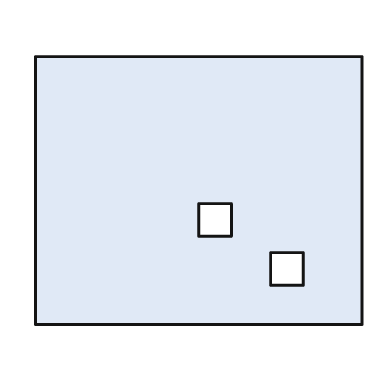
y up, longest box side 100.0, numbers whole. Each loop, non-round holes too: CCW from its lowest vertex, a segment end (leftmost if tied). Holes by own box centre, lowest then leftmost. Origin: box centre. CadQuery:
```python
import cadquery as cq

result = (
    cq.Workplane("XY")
    .moveTo(-50.0, -41.0)
    .lineTo(50.0, -41.0)
    .lineTo(50.0, 41.0)
    .lineTo(-50.0, 41.0)
    .close()
    .moveTo(22.0, -29.0)
    .lineTo(32.0, -29.0)
    .lineTo(32.0, -19.0)
    .lineTo(22.0, -19.0)
    .close()
    .moveTo(0.0, -14.0)
    .lineTo(10.0, -14.0)
    .lineTo(10.0, -4.0)
    .lineTo(0.0, -4.0)
    .close()
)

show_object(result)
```